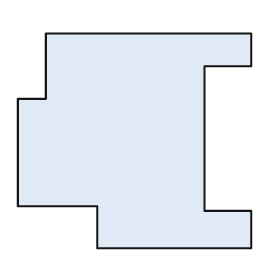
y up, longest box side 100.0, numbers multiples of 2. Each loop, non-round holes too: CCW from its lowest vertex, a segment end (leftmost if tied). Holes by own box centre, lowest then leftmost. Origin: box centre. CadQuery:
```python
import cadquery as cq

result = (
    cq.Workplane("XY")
    .moveTo(-16.0, -46.0)
    .lineTo(50.0, -46.0)
    .lineTo(50.0, -30.0)
    .lineTo(30.0, -30.0)
    .lineTo(30.0, 32.0)
    .lineTo(50.0, 32.0)
    .lineTo(50.0, 46.0)
    .lineTo(-38.0, 46.0)
    .lineTo(-38.0, 18.0)
    .lineTo(-50.0, 18.0)
    .lineTo(-50.0, -28.0)
    .lineTo(-16.0, -28.0)
    .close()
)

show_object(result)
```